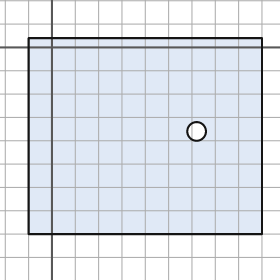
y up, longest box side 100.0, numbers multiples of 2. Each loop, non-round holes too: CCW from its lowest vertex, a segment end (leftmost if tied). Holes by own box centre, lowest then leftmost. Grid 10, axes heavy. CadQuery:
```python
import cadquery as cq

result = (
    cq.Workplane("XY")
    .moveTo(-10.0, -80.0)
    .lineTo(90.0, -80.0)
    .lineTo(90.0, 4.0)
    .lineTo(-10.0, 4.0)
    .close()
    .moveTo(62.0, -36.0)
    .circle(4.0)
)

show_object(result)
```